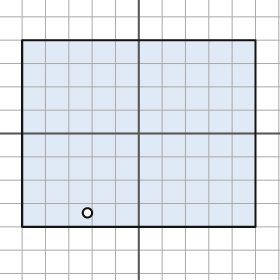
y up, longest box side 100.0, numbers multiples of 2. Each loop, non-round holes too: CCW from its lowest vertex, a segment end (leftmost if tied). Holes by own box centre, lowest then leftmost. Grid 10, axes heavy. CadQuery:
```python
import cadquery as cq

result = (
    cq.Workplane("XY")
    .moveTo(-50.0, -40.0)
    .lineTo(50.0, -40.0)
    .lineTo(50.0, 40.0)
    .lineTo(-50.0, 40.0)
    .close()
    .moveTo(-22.0, -34.0)
    .circle(2.0)
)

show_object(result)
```